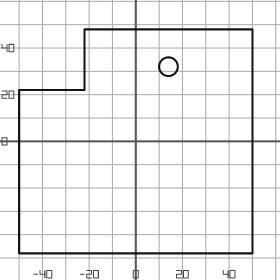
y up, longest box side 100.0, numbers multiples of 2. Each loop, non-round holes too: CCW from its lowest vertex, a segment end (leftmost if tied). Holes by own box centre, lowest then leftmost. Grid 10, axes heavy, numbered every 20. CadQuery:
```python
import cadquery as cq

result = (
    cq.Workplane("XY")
    .moveTo(-50.0, -48.0)
    .lineTo(50.0, -48.0)
    .lineTo(50.0, 48.0)
    .lineTo(-22.0, 48.0)
    .lineTo(-22.0, 22.0)
    .lineTo(-50.0, 22.0)
    .close()
    .moveTo(14.0, 32.0)
    .circle(4.0)
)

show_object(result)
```